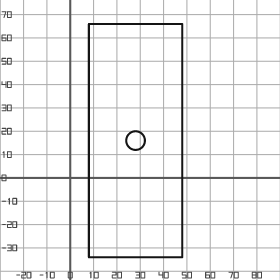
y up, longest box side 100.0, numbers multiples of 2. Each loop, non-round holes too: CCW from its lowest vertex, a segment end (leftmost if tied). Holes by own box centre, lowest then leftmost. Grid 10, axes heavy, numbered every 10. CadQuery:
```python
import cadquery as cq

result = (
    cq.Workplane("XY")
    .moveTo(8.0, -34.0)
    .lineTo(48.0, -34.0)
    .lineTo(48.0, 66.0)
    .lineTo(8.0, 66.0)
    .close()
    .moveTo(28.0, 16.0)
    .circle(4.0)
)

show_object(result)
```